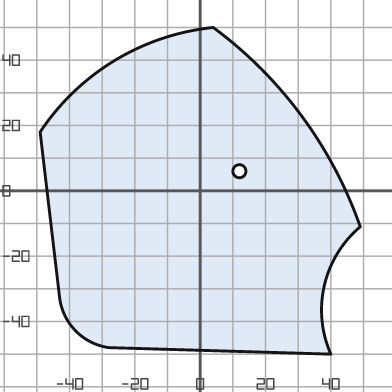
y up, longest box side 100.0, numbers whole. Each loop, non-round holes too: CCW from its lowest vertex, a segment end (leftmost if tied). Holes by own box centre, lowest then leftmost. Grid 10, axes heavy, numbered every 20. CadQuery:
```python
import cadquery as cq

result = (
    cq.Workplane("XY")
    .moveTo(40.0, -50.0)
    .threePointArc((38.0, -29.0), (49.0, -11.0))
    .threePointArc((31.0, 23.0), (4.0, 50.0))
    .threePointArc((-26.0, 40.0), (-49.0, 18.0))
    .lineTo(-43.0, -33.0)
    .threePointArc((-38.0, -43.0), (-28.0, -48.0))
    .close()
    .moveTo(12.0, 6.0)
    .circle(2.0)
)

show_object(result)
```